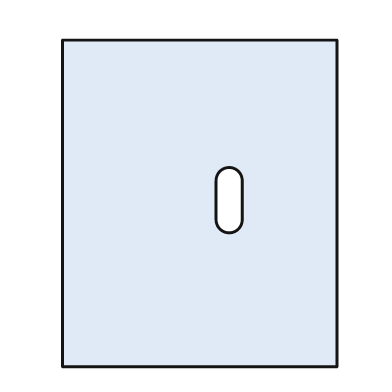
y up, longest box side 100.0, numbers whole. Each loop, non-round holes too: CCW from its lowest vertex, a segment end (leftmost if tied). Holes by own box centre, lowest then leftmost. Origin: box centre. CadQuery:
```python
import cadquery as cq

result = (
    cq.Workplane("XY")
    .moveTo(-42.0, -50.0)
    .lineTo(42.0, -50.0)
    .lineTo(42.0, 50.0)
    .lineTo(-42.0, 50.0)
    .close()
    .moveTo(5.0, -5.0)
    .threePointArc((9.0, -9.0), (13.0, -5.0))
    .lineTo(13.0, 7.0)
    .threePointArc((9.0, 11.0), (5.0, 7.0))
    .close()
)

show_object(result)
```